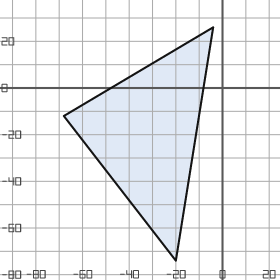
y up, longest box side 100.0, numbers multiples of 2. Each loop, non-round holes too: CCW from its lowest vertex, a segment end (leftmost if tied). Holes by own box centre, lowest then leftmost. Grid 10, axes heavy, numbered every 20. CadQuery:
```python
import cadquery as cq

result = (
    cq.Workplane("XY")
    .moveTo(-20.0, -74.0)
    .lineTo(-4.0, 26.0)
    .lineTo(-68.0, -12.0)
    .close()
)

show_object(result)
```